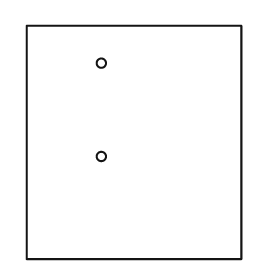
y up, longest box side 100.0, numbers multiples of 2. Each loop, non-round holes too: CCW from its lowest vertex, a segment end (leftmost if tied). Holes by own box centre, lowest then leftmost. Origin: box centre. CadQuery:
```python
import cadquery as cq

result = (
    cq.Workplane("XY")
    .moveTo(-46.0, -50.0)
    .lineTo(46.0, -50.0)
    .lineTo(46.0, 50.0)
    .lineTo(-46.0, 50.0)
    .close()
    .moveTo(-14.0, -6.0)
    .circle(2.0)
    .moveTo(-14.0, 34.0)
    .circle(2.0)
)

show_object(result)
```